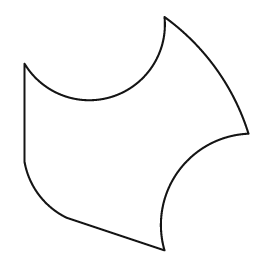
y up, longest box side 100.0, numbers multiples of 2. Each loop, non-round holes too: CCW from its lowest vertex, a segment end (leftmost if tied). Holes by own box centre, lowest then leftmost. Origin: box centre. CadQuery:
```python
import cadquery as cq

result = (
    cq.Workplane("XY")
    .moveTo(12.0, -50.0)
    .threePointArc((18.0, -16.0), (48.0, 0.0))
    .threePointArc((34.0, 28.0), (12.0, 50.0))
    .threePointArc((-10.0, 16.0), (-48.0, 30.0))
    .lineTo(-48.0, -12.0)
    .threePointArc((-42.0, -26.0), (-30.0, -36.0))
    .close()
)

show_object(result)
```